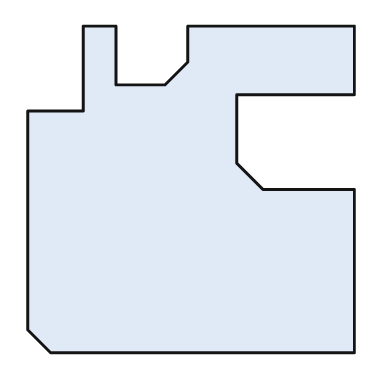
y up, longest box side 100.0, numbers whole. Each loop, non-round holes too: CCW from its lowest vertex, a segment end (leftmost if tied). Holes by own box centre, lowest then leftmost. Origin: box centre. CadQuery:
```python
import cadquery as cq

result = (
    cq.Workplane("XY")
    .moveTo(-43.0, -50.0)
    .lineTo(50.0, -50.0)
    .lineTo(50.0, 0.0)
    .lineTo(22.0, 0.0)
    .lineTo(14.0, 8.0)
    .lineTo(14.0, 29.0)
    .lineTo(50.0, 29.0)
    .lineTo(50.0, 50.0)
    .lineTo(-1.0, 50.0)
    .lineTo(-1.0, 39.0)
    .lineTo(-8.0, 32.0)
    .lineTo(-23.0, 32.0)
    .lineTo(-23.0, 50.0)
    .lineTo(-33.0, 50.0)
    .lineTo(-33.0, 24.0)
    .lineTo(-50.0, 24.0)
    .lineTo(-50.0, -43.0)
    .close()
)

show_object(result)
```